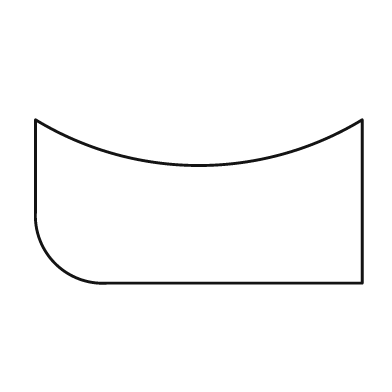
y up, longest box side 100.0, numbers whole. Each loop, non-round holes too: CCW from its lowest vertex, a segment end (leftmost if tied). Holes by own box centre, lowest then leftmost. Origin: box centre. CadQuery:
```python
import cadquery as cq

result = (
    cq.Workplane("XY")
    .moveTo(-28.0, -25.0)
    .lineTo(50.0, -25.0)
    .lineTo(50.0, 25.0)
    .threePointArc((0.0, 11.0), (-50.0, 25.0))
    .lineTo(-50.0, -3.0)
    .threePointArc((-44.0, -19.0), (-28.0, -25.0))
    .close()
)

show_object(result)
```